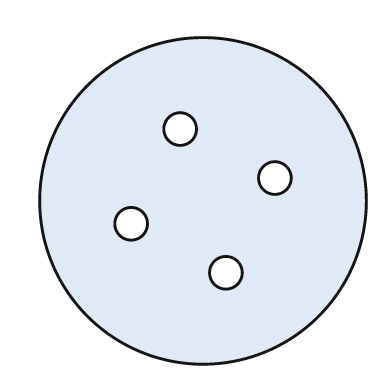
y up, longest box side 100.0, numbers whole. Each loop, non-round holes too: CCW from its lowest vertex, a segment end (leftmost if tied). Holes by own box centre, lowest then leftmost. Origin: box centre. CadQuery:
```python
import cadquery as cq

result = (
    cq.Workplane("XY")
    .moveTo(0.0, 0.0)
    .circle(50.0)
    .moveTo(7.0, -22.0)
    .circle(5.0)
    .moveTo(-22.0, -7.0)
    .circle(5.0)
    .moveTo(22.0, 7.0)
    .circle(5.0)
    .moveTo(-7.0, 22.0)
    .circle(5.0)
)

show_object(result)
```